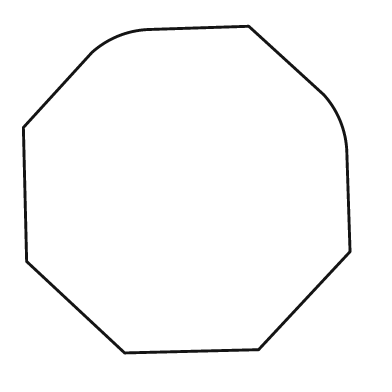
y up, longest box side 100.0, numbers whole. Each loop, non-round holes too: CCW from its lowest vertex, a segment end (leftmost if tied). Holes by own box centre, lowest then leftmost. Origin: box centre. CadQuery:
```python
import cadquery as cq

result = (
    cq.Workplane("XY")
    .moveTo(-19.0, -50.0)
    .lineTo(22.0, -49.0)
    .lineTo(50.0, -19.0)
    .lineTo(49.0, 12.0)
    .threePointArc((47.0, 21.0), (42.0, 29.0))
    .lineTo(19.0, 50.0)
    .lineTo(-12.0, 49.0)
    .threePointArc((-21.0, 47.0), (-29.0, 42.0))
    .lineTo(-50.0, 19.0)
    .lineTo(-49.0, -22.0)
    .close()
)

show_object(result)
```